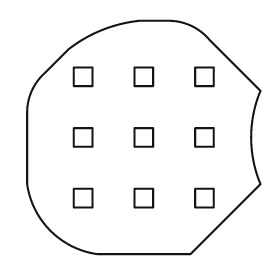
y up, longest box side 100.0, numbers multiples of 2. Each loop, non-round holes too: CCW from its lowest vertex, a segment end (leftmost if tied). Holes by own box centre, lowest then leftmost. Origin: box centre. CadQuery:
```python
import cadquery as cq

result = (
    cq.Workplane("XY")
    .moveTo(-20.0, -50.0)
    .lineTo(20.0, -50.0)
    .lineTo(50.0, -20.0)
    .threePointArc((46.0, 0.0), (50.0, 20.0))
    .lineTo(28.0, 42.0)
    .threePointArc((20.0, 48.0), (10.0, 50.0))
    .lineTo(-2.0, 50.0)
    .threePointArc((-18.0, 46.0), (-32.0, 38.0))
    .lineTo(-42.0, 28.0)
    .threePointArc((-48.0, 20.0), (-50.0, 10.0))
    .lineTo(-50.0, -20.0)
    .threePointArc((-40.0, -40.0), (-20.0, -50.0))
    .close()
    .moveTo(-30.0, -30.0)
    .lineTo(-22.0, -30.0)
    .lineTo(-22.0, -22.0)
    .lineTo(-30.0, -22.0)
    .close()
    .moveTo(-4.0, -30.0)
    .lineTo(4.0, -30.0)
    .lineTo(4.0, -22.0)
    .lineTo(-4.0, -22.0)
    .close()
    .moveTo(22.0, -30.0)
    .lineTo(30.0, -30.0)
    .lineTo(30.0, -22.0)
    .lineTo(22.0, -22.0)
    .close()
    .moveTo(-30.0, -4.0)
    .lineTo(-22.0, -4.0)
    .lineTo(-22.0, 4.0)
    .lineTo(-30.0, 4.0)
    .close()
    .moveTo(-4.0, -4.0)
    .lineTo(4.0, -4.0)
    .lineTo(4.0, 4.0)
    .lineTo(-4.0, 4.0)
    .close()
    .moveTo(22.0, -4.0)
    .lineTo(30.0, -4.0)
    .lineTo(30.0, 4.0)
    .lineTo(22.0, 4.0)
    .close()
    .moveTo(-30.0, 22.0)
    .lineTo(-22.0, 22.0)
    .lineTo(-22.0, 30.0)
    .lineTo(-30.0, 30.0)
    .close()
    .moveTo(-4.0, 22.0)
    .lineTo(4.0, 22.0)
    .lineTo(4.0, 30.0)
    .lineTo(-4.0, 30.0)
    .close()
    .moveTo(22.0, 22.0)
    .lineTo(30.0, 22.0)
    .lineTo(30.0, 30.0)
    .lineTo(22.0, 30.0)
    .close()
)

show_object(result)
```